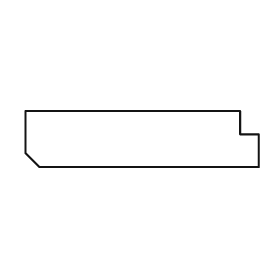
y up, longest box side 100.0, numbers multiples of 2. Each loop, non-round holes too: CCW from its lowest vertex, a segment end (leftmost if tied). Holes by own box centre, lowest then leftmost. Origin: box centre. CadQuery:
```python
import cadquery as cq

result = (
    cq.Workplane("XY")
    .moveTo(-44.0, -12.0)
    .lineTo(50.0, -12.0)
    .lineTo(50.0, 2.0)
    .lineTo(42.0, 2.0)
    .lineTo(42.0, 12.0)
    .lineTo(-50.0, 12.0)
    .lineTo(-50.0, -6.0)
    .close()
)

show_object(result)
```